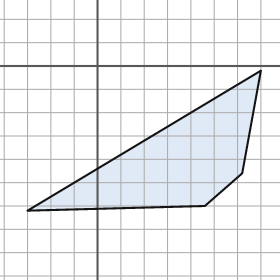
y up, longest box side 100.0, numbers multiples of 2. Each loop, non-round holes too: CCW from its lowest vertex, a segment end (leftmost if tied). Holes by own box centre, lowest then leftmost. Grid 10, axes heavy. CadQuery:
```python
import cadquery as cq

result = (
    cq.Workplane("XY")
    .moveTo(-30.0, -62.0)
    .lineTo(46.0, -60.0)
    .lineTo(62.0, -46.0)
    .lineTo(70.0, -2.0)
    .close()
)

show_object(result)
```